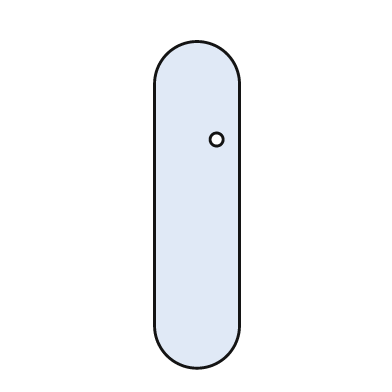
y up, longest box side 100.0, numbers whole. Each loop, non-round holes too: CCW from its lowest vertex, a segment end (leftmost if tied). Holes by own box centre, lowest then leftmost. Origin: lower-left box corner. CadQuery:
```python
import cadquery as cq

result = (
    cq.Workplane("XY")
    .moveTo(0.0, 13.0)
    .threePointArc((13.0, 0.0), (26.0, 13.0))
    .lineTo(26.0, 87.0)
    .threePointArc((13.0, 100.0), (0.0, 87.0))
    .close()
    .moveTo(19.0, 70.0)
    .circle(2.0)
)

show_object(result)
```